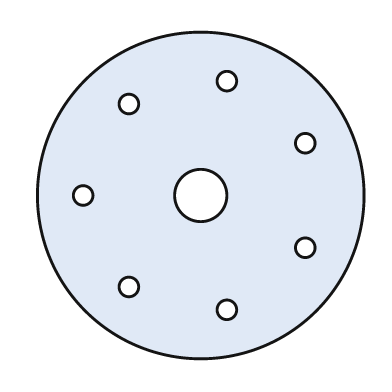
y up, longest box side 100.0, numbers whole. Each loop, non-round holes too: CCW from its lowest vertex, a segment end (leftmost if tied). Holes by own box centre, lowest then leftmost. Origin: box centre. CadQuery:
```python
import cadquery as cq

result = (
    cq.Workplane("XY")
    .moveTo(0.0, 0.0)
    .circle(50.0)
    .moveTo(8.0, -35.0)
    .circle(3.0)
    .moveTo(-22.0, -28.0)
    .circle(3.0)
    .moveTo(32.0, -16.0)
    .circle(3.0)
    .moveTo(-36.0, 0.0)
    .circle(3.0)
    .moveTo(0.0, 0.0)
    .circle(8.0)
    .moveTo(32.0, 16.0)
    .circle(3.0)
    .moveTo(-22.0, 28.0)
    .circle(3.0)
    .moveTo(8.0, 35.0)
    .circle(3.0)
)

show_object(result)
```